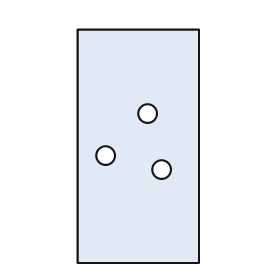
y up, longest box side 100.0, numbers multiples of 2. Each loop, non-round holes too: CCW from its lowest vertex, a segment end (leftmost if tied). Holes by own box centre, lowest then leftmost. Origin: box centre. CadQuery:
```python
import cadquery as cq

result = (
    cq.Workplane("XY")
    .moveTo(-26.0, -50.0)
    .lineTo(26.0, -50.0)
    .lineTo(26.0, 50.0)
    .lineTo(-26.0, 50.0)
    .close()
    .moveTo(10.0, -10.0)
    .circle(4.0)
    .moveTo(-14.0, -4.0)
    .circle(4.0)
    .moveTo(4.0, 14.0)
    .circle(4.0)
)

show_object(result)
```